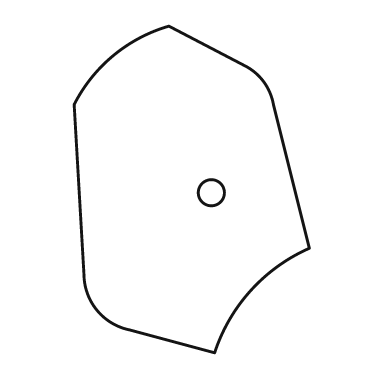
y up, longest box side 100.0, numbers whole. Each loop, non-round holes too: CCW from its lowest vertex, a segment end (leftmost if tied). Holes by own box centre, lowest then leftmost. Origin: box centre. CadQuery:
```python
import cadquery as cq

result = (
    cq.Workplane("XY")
    .moveTo(7.0, -50.0)
    .threePointArc((18.0, -31.0), (36.0, -18.0))
    .lineTo(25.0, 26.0)
    .threePointArc((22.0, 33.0), (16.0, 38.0))
    .lineTo(-7.0, 50.0)
    .threePointArc((-24.0, 41.0), (-36.0, 26.0))
    .lineTo(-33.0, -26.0)
    .threePointArc((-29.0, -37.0), (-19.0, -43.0))
    .close()
    .moveTo(6.0, -1.0)
    .circle(4.0)
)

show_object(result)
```